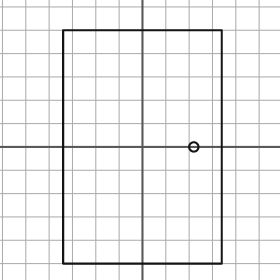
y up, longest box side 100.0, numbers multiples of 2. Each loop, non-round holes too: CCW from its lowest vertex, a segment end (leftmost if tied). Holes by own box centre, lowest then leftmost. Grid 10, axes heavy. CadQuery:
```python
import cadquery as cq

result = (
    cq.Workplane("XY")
    .moveTo(-34.0, -50.0)
    .lineTo(34.0, -50.0)
    .lineTo(34.0, 50.0)
    .lineTo(-34.0, 50.0)
    .close()
    .moveTo(22.0, 0.0)
    .circle(2.0)
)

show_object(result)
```